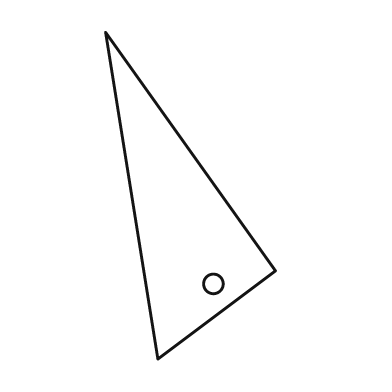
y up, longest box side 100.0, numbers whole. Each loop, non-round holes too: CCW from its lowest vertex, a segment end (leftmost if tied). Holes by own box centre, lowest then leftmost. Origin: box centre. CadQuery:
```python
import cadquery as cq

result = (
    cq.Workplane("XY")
    .moveTo(-10.0, -50.0)
    .lineTo(26.0, -23.0)
    .lineTo(-26.0, 50.0)
    .close()
    .moveTo(7.0, -27.0)
    .circle(3.0)
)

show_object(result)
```